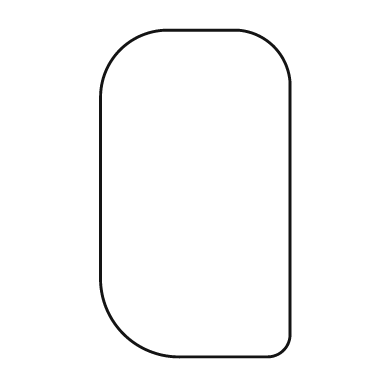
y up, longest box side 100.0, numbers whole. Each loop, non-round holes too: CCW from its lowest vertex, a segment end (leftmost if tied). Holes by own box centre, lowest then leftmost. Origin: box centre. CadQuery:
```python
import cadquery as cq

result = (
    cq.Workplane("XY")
    .moveTo(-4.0, -50.0)
    .lineTo(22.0, -50.0)
    .threePointArc((27.0, -48.0), (29.0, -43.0))
    .lineTo(29.0, 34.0)
    .threePointArc((24.0, 45.0), (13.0, 50.0))
    .lineTo(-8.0, 50.0)
    .threePointArc((-23.0, 44.0), (-29.0, 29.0))
    .lineTo(-29.0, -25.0)
    .threePointArc((-22.0, -43.0), (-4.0, -50.0))
    .close()
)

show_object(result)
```